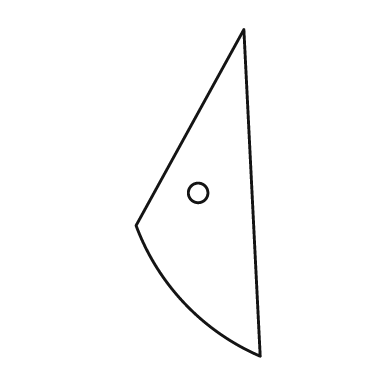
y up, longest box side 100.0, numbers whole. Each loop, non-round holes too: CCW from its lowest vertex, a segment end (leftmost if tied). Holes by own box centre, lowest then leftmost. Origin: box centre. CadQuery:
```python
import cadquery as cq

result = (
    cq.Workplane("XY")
    .moveTo(19.0, -50.0)
    .lineTo(14.0, 50.0)
    .lineTo(-19.0, -10.0)
    .threePointArc((-4.0, -34.0), (19.0, -50.0))
    .close()
    .moveTo(0.0, 0.0)
    .circle(3.0)
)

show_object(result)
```